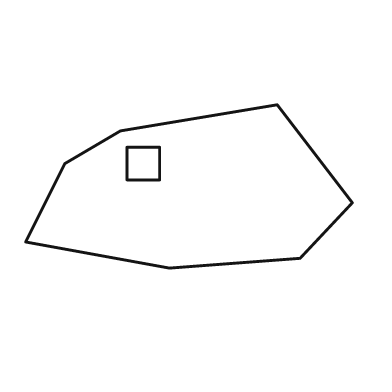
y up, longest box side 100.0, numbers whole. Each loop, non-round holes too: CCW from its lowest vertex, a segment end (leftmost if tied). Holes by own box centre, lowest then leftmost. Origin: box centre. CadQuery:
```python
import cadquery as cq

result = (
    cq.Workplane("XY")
    .moveTo(-6.0, -25.0)
    .lineTo(34.0, -22.0)
    .lineTo(50.0, -5.0)
    .lineTo(27.0, 25.0)
    .lineTo(-21.0, 17.0)
    .lineTo(-38.0, 7.0)
    .lineTo(-50.0, -17.0)
    .close()
    .moveTo(-19.0, 2.0)
    .lineTo(-9.0, 2.0)
    .lineTo(-9.0, 12.0)
    .lineTo(-19.0, 12.0)
    .close()
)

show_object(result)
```